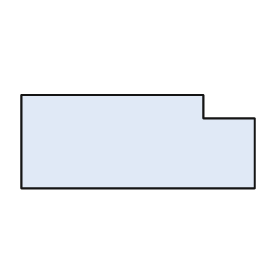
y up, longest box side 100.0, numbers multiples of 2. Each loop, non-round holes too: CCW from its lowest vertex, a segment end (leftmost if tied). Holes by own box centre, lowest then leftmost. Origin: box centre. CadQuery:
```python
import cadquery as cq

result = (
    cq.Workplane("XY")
    .moveTo(-50.0, -20.0)
    .lineTo(50.0, -20.0)
    .lineTo(50.0, 10.0)
    .lineTo(28.0, 10.0)
    .lineTo(28.0, 20.0)
    .lineTo(-50.0, 20.0)
    .close()
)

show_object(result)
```